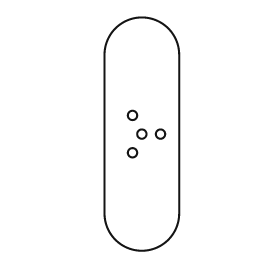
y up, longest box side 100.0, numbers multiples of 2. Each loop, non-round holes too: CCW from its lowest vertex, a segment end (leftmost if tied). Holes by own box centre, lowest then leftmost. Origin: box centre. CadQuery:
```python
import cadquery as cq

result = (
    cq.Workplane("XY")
    .moveTo(-16.0, -34.0)
    .threePointArc((0.0, -50.0), (16.0, -34.0))
    .lineTo(16.0, 34.0)
    .threePointArc((0.0, 50.0), (-16.0, 34.0))
    .close()
    .moveTo(-4.0, -8.0)
    .circle(2.0)
    .moveTo(0.0, 0.0)
    .circle(2.0)
    .moveTo(8.0, 0.0)
    .circle(2.0)
    .moveTo(-4.0, 8.0)
    .circle(2.0)
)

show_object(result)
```